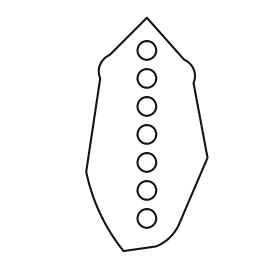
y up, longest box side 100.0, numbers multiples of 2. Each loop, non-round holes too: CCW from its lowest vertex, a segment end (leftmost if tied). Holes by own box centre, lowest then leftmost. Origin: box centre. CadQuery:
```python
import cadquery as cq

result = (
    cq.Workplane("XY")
    .moveTo(-10.0, -50.0)
    .lineTo(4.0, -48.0)
    .threePointArc((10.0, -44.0), (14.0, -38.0))
    .lineTo(26.0, -10.0)
    .lineTo(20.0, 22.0)
    .threePointArc((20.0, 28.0), (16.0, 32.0))
    .lineTo(0.0, 50.0)
    .lineTo(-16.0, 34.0)
    .threePointArc((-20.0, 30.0), (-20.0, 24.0))
    .lineTo(-26.0, -16.0)
    .threePointArc((-20.0, -34.0), (-10.0, -50.0))
    .close()
    .moveTo(0.0, -36.0)
    .circle(4.0)
    .moveTo(0.0, -24.0)
    .circle(4.0)
    .moveTo(0.0, -12.0)
    .circle(4.0)
    .moveTo(0.0, 0.0)
    .circle(4.0)
    .moveTo(0.0, 12.0)
    .circle(4.0)
    .moveTo(0.0, 24.0)
    .circle(4.0)
    .moveTo(0.0, 36.0)
    .circle(4.0)
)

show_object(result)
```